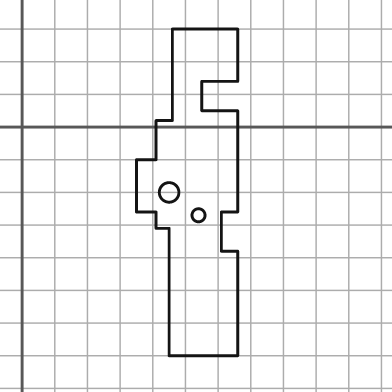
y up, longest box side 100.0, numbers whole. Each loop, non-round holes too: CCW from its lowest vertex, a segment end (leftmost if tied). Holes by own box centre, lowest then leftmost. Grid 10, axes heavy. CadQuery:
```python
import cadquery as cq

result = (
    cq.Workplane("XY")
    .moveTo(45.0, -70.0)
    .lineTo(66.0, -70.0)
    .lineTo(66.0, -38.0)
    .lineTo(61.0, -38.0)
    .lineTo(61.0, -26.0)
    .lineTo(66.0, -26.0)
    .lineTo(66.0, 5.0)
    .lineTo(55.0, 5.0)
    .lineTo(55.0, 14.0)
    .lineTo(66.0, 14.0)
    .lineTo(66.0, 30.0)
    .lineTo(46.0, 30.0)
    .lineTo(46.0, 2.0)
    .lineTo(41.0, 2.0)
    .lineTo(41.0, -10.0)
    .lineTo(35.0, -10.0)
    .lineTo(35.0, -26.0)
    .lineTo(41.0, -26.0)
    .lineTo(41.0, -31.0)
    .lineTo(45.0, -31.0)
    .close()
    .moveTo(54.0, -27.0)
    .circle(2.0)
    .moveTo(45.0, -20.0)
    .circle(3.0)
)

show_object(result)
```